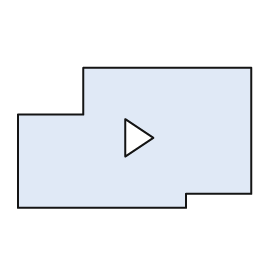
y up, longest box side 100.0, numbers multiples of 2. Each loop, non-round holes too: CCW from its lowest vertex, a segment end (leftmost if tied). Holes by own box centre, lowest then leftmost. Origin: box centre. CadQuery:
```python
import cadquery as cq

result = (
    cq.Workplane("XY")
    .moveTo(-50.0, -30.0)
    .lineTo(22.0, -30.0)
    .lineTo(22.0, -24.0)
    .lineTo(50.0, -24.0)
    .lineTo(50.0, 30.0)
    .lineTo(-22.0, 30.0)
    .lineTo(-22.0, 10.0)
    .lineTo(-50.0, 10.0)
    .close()
    .moveTo(-4.0, -8.0)
    .lineTo(8.0, 0.0)
    .lineTo(-4.0, 8.0)
    .close()
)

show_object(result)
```